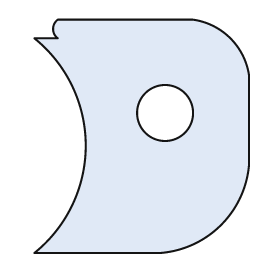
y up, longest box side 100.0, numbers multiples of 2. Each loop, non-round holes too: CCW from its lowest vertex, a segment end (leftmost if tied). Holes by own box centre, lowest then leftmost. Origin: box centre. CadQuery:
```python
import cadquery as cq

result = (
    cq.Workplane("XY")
    .moveTo(-46.0, -50.0)
    .lineTo(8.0, -50.0)
    .threePointArc((34.0, -38.0), (46.0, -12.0))
    .lineTo(46.0, 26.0)
    .threePointArc((38.0, 42.0), (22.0, 50.0))
    .lineTo(-36.0, 50.0)
    .threePointArc((-38.0, 46.0), (-36.0, 42.0))
    .lineTo(-46.0, 42.0)
    .threePointArc((-24.0, -4.0), (-46.0, -50.0))
    .close()
    .moveTo(10.0, 10.0)
    .circle(12.0)
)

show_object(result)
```